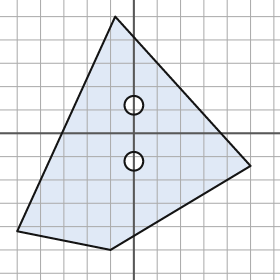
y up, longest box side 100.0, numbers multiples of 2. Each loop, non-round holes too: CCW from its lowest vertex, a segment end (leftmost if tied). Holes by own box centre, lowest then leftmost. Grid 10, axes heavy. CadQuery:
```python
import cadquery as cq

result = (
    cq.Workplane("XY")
    .moveTo(-10.0, -50.0)
    .lineTo(50.0, -14.0)
    .lineTo(-8.0, 50.0)
    .lineTo(-50.0, -42.0)
    .close()
    .moveTo(0.0, -12.0)
    .circle(4.0)
    .moveTo(0.0, 12.0)
    .circle(4.0)
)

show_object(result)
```